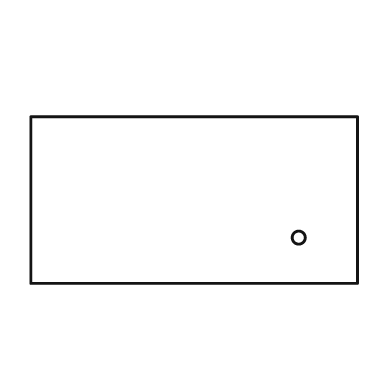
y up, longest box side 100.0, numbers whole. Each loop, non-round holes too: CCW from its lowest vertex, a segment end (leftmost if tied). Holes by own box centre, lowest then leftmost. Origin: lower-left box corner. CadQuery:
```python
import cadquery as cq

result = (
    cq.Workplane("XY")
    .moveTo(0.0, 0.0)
    .lineTo(100.0, 0.0)
    .lineTo(100.0, 51.0)
    .lineTo(0.0, 51.0)
    .close()
    .moveTo(82.0, 14.0)
    .circle(2.0)
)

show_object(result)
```